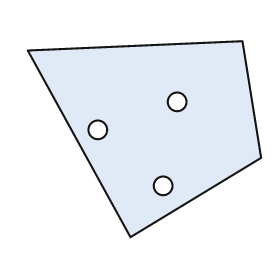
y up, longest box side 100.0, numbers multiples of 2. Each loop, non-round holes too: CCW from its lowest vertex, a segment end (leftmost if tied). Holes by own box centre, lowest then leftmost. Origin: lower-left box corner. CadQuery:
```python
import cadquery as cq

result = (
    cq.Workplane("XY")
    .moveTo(44.0, 0.0)
    .lineTo(100.0, 34.0)
    .lineTo(92.0, 84.0)
    .lineTo(0.0, 80.0)
    .close()
    .moveTo(58.0, 22.0)
    .circle(4.0)
    .moveTo(30.0, 46.0)
    .circle(4.0)
    .moveTo(64.0, 58.0)
    .circle(4.0)
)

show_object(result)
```